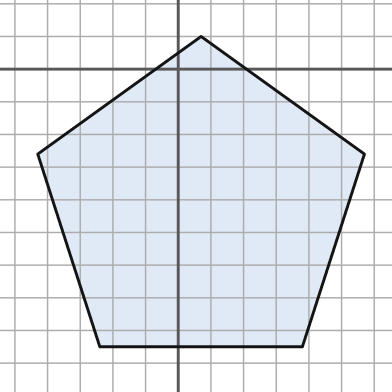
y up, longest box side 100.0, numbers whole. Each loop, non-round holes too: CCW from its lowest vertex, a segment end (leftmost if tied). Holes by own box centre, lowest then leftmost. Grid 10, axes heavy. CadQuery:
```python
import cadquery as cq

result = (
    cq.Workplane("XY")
    .moveTo(-24.0, -85.0)
    .lineTo(38.0, -85.0)
    .lineTo(57.0, -26.0)
    .lineTo(7.0, 10.0)
    .lineTo(-43.0, -26.0)
    .close()
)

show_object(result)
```